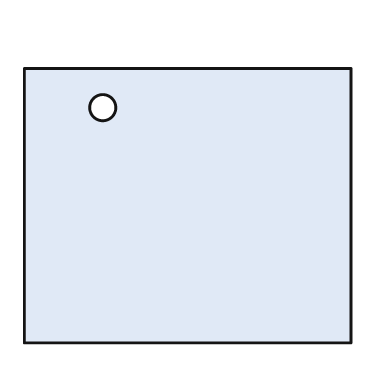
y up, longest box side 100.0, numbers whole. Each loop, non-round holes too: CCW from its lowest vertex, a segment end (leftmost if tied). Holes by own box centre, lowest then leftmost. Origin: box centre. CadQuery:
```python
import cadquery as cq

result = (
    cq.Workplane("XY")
    .moveTo(-50.0, -42.0)
    .lineTo(50.0, -42.0)
    .lineTo(50.0, 42.0)
    .lineTo(-50.0, 42.0)
    .close()
    .moveTo(-26.0, 30.0)
    .circle(4.0)
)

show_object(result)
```